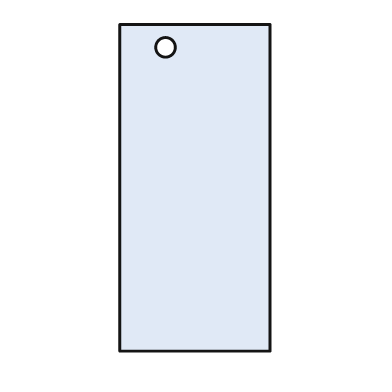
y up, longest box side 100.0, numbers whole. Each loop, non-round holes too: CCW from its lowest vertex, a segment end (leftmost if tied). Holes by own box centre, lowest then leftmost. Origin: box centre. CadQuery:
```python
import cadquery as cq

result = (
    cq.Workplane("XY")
    .moveTo(-23.0, -50.0)
    .lineTo(23.0, -50.0)
    .lineTo(23.0, 50.0)
    .lineTo(-23.0, 50.0)
    .close()
    .moveTo(-9.0, 43.0)
    .circle(3.0)
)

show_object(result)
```